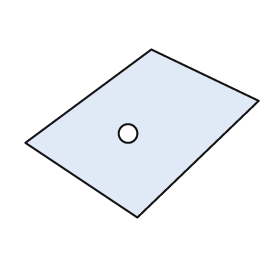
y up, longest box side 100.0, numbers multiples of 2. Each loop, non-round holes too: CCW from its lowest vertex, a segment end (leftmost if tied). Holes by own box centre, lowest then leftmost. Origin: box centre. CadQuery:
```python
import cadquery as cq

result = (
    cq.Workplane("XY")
    .moveTo(-2.0, -36.0)
    .lineTo(50.0, 14.0)
    .lineTo(4.0, 36.0)
    .lineTo(-50.0, -4.0)
    .close()
    .moveTo(-6.0, 0.0)
    .circle(4.0)
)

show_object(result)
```